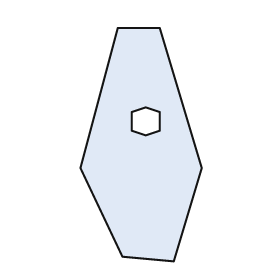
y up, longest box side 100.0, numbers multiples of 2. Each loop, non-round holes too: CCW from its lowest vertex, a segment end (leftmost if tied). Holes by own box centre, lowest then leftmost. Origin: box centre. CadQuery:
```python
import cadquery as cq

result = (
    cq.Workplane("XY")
    .moveTo(14.0, -50.0)
    .lineTo(26.0, -10.0)
    .lineTo(8.0, 50.0)
    .lineTo(-10.0, 50.0)
    .lineTo(-26.0, -10.0)
    .lineTo(-8.0, -48.0)
    .close()
    .moveTo(2.0, 4.0)
    .lineTo(8.0, 6.0)
    .lineTo(8.0, 14.0)
    .lineTo(2.0, 16.0)
    .lineTo(-4.0, 14.0)
    .lineTo(-4.0, 6.0)
    .close()
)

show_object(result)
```